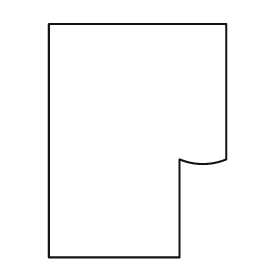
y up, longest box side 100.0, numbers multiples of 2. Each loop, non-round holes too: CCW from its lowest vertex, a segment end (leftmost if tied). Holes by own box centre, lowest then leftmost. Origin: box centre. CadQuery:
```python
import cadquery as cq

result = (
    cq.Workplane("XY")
    .moveTo(-38.0, -50.0)
    .lineTo(18.0, -50.0)
    .lineTo(18.0, -8.0)
    .threePointArc((28.0, -10.0), (38.0, -8.0))
    .lineTo(38.0, 50.0)
    .lineTo(-38.0, 50.0)
    .close()
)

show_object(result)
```